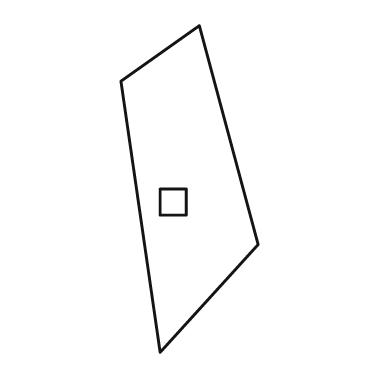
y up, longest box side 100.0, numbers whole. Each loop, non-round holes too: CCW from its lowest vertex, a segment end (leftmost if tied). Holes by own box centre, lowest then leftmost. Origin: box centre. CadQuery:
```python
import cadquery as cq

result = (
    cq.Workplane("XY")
    .moveTo(-9.0, -50.0)
    .lineTo(21.0, -17.0)
    .lineTo(3.0, 50.0)
    .lineTo(-21.0, 33.0)
    .close()
    .moveTo(-9.0, -8.0)
    .lineTo(-1.0, -8.0)
    .lineTo(-1.0, 0.0)
    .lineTo(-9.0, 0.0)
    .close()
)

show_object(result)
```